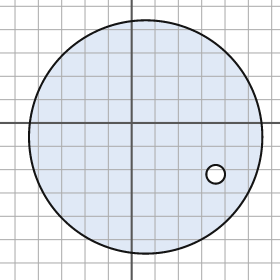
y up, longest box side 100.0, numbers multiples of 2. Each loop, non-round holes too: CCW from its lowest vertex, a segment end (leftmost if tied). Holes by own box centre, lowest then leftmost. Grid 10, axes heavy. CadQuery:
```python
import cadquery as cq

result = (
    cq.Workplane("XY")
    .moveTo(6.0, -6.0)
    .circle(50.0)
    .moveTo(36.0, -22.0)
    .circle(4.0)
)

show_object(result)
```